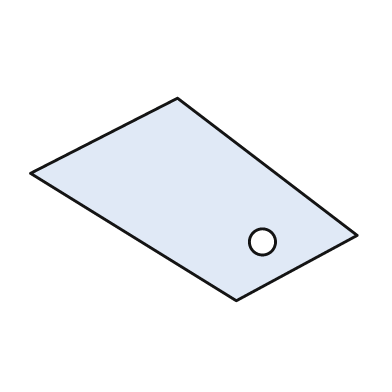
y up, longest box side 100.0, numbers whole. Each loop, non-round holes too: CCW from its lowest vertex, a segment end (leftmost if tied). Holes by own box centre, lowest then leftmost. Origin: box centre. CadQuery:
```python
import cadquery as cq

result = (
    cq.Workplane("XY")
    .moveTo(13.0, -31.0)
    .lineTo(50.0, -11.0)
    .lineTo(-5.0, 31.0)
    .lineTo(-50.0, 8.0)
    .close()
    .moveTo(21.0, -13.0)
    .circle(4.0)
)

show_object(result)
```